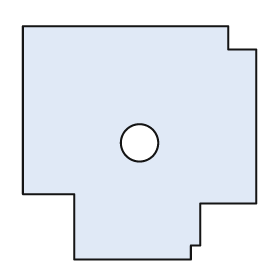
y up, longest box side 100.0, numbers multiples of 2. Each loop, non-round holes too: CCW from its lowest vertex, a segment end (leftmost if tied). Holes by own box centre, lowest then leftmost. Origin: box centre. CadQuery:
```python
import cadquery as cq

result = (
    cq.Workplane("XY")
    .moveTo(-28.0, -50.0)
    .lineTo(22.0, -50.0)
    .lineTo(22.0, -44.0)
    .lineTo(26.0, -44.0)
    .lineTo(26.0, -26.0)
    .lineTo(50.0, -26.0)
    .lineTo(50.0, 40.0)
    .lineTo(38.0, 40.0)
    .lineTo(38.0, 50.0)
    .lineTo(-50.0, 50.0)
    .lineTo(-50.0, -22.0)
    .lineTo(-28.0, -22.0)
    .close()
    .moveTo(0.0, 0.0)
    .circle(8.0)
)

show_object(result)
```